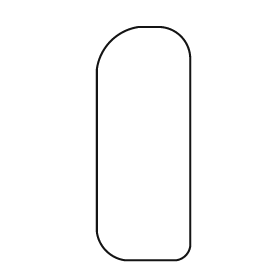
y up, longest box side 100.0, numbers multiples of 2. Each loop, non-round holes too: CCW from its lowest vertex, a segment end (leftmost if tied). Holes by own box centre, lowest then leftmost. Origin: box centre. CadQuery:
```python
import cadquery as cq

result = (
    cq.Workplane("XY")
    .moveTo(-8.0, -50.0)
    .lineTo(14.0, -50.0)
    .threePointArc((18.0, -48.0), (20.0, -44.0))
    .lineTo(20.0, 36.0)
    .threePointArc((16.0, 46.0), (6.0, 50.0))
    .lineTo(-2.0, 50.0)
    .threePointArc((-14.0, 44.0), (-20.0, 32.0))
    .lineTo(-20.0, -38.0)
    .threePointArc((-16.0, -46.0), (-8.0, -50.0))
    .close()
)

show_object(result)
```